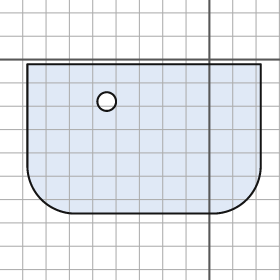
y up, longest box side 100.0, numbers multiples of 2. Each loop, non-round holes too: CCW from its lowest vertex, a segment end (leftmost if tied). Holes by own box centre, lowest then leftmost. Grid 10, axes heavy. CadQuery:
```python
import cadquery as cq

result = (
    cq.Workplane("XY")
    .moveTo(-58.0, -66.0)
    .lineTo(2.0, -66.0)
    .threePointArc((16.0, -60.0), (22.0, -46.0))
    .lineTo(22.0, -2.0)
    .lineTo(-78.0, -2.0)
    .lineTo(-78.0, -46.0)
    .threePointArc((-72.0, -60.0), (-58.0, -66.0))
    .close()
    .moveTo(-44.0, -18.0)
    .circle(4.0)
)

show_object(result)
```